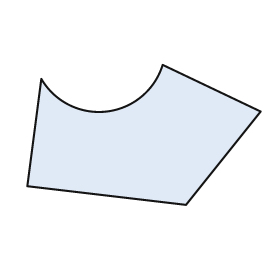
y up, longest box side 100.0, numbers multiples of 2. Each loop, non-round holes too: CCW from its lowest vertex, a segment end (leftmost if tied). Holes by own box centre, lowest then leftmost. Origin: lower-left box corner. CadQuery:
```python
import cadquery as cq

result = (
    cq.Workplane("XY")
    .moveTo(68.0, 0.0)
    .lineTo(100.0, 40.0)
    .lineTo(58.0, 60.0)
    .threePointArc((34.0, 40.0), (6.0, 54.0))
    .lineTo(0.0, 8.0)
    .close()
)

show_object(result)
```